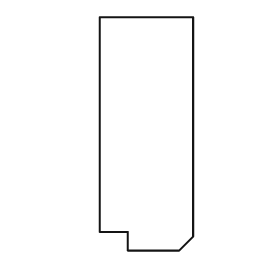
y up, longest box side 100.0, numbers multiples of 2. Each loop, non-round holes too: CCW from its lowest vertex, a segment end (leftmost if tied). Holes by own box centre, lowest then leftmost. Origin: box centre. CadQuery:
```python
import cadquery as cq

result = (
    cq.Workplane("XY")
    .moveTo(-8.0, -50.0)
    .lineTo(14.0, -50.0)
    .lineTo(20.0, -44.0)
    .lineTo(20.0, 50.0)
    .lineTo(-20.0, 50.0)
    .lineTo(-20.0, -42.0)
    .lineTo(-8.0, -42.0)
    .close()
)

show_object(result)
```